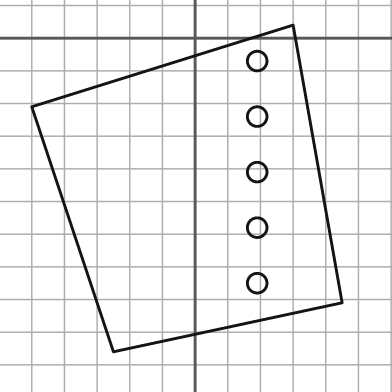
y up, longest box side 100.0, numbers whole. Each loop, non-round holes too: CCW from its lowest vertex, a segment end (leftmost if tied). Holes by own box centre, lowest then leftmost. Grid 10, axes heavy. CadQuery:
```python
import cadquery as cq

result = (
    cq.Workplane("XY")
    .moveTo(-25.0, -96.0)
    .lineTo(45.0, -81.0)
    .lineTo(30.0, 4.0)
    .lineTo(-50.0, -21.0)
    .close()
    .moveTo(19.0, -75.0)
    .circle(3.0)
    .moveTo(19.0, -58.0)
    .circle(3.0)
    .moveTo(19.0, -41.0)
    .circle(3.0)
    .moveTo(19.0, -24.0)
    .circle(3.0)
    .moveTo(19.0, -7.0)
    .circle(3.0)
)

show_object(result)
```